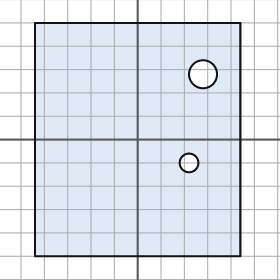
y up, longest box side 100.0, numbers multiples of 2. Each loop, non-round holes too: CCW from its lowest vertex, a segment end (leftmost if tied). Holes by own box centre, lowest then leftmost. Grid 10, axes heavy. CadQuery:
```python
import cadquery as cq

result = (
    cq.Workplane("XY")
    .moveTo(-44.0, -50.0)
    .lineTo(44.0, -50.0)
    .lineTo(44.0, 50.0)
    .lineTo(-44.0, 50.0)
    .close()
    .moveTo(22.0, -10.0)
    .circle(4.0)
    .moveTo(28.0, 28.0)
    .circle(6.0)
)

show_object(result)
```